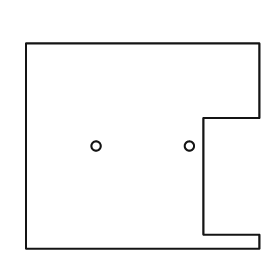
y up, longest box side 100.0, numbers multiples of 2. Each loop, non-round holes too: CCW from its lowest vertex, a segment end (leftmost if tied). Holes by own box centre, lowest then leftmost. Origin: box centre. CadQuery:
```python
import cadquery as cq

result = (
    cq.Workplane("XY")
    .moveTo(-50.0, -44.0)
    .lineTo(50.0, -44.0)
    .lineTo(50.0, -38.0)
    .lineTo(26.0, -38.0)
    .lineTo(26.0, 12.0)
    .lineTo(50.0, 12.0)
    .lineTo(50.0, 44.0)
    .lineTo(-50.0, 44.0)
    .close()
    .moveTo(-20.0, 0.0)
    .circle(2.0)
    .moveTo(20.0, 0.0)
    .circle(2.0)
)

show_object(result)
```